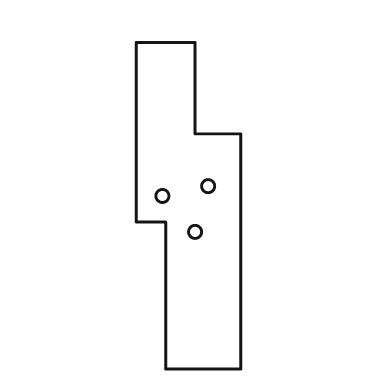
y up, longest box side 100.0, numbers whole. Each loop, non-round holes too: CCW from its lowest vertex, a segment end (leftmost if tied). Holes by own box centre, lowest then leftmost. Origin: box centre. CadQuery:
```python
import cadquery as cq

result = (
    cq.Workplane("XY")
    .moveTo(-7.0, -50.0)
    .lineTo(16.0, -50.0)
    .lineTo(16.0, 22.0)
    .lineTo(2.0, 22.0)
    .lineTo(2.0, 50.0)
    .lineTo(-16.0, 50.0)
    .lineTo(-16.0, -5.0)
    .lineTo(-7.0, -5.0)
    .close()
    .moveTo(2.0, -8.0)
    .circle(2.0)
    .moveTo(-8.0, 3.0)
    .circle(2.0)
    .moveTo(6.0, 6.0)
    .circle(2.0)
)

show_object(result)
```